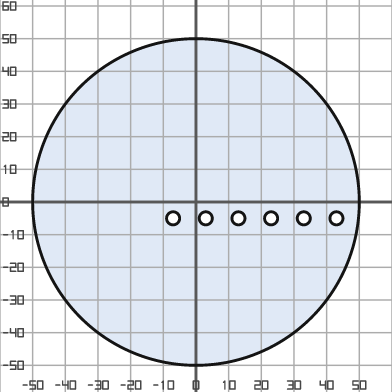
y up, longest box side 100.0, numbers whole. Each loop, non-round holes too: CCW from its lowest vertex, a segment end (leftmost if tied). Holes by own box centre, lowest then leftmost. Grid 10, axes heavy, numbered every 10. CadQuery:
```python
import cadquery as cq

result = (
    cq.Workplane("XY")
    .moveTo(0.0, 0.0)
    .circle(50.0)
    .moveTo(-7.0, -5.0)
    .circle(2.0)
    .moveTo(3.0, -5.0)
    .circle(2.0)
    .moveTo(13.0, -5.0)
    .circle(2.0)
    .moveTo(23.0, -5.0)
    .circle(2.0)
    .moveTo(33.0, -5.0)
    .circle(2.0)
    .moveTo(43.0, -5.0)
    .circle(2.0)
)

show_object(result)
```